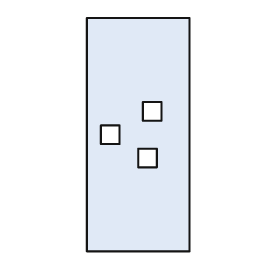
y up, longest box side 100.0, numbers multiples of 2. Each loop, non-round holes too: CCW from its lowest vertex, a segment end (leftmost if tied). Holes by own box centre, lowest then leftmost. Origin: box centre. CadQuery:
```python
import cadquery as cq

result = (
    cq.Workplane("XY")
    .moveTo(-22.0, -50.0)
    .lineTo(22.0, -50.0)
    .lineTo(22.0, 50.0)
    .lineTo(-22.0, 50.0)
    .close()
    .moveTo(0.0, -14.0)
    .lineTo(8.0, -14.0)
    .lineTo(8.0, -6.0)
    .lineTo(0.0, -6.0)
    .close()
    .moveTo(-16.0, -4.0)
    .lineTo(-8.0, -4.0)
    .lineTo(-8.0, 4.0)
    .lineTo(-16.0, 4.0)
    .close()
    .moveTo(2.0, 6.0)
    .lineTo(10.0, 6.0)
    .lineTo(10.0, 14.0)
    .lineTo(2.0, 14.0)
    .close()
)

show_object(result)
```